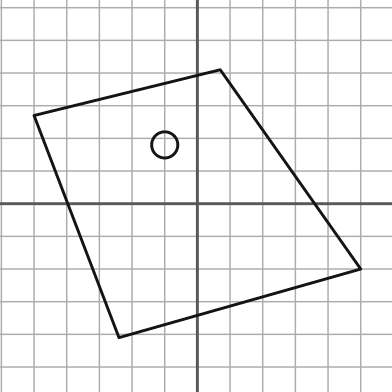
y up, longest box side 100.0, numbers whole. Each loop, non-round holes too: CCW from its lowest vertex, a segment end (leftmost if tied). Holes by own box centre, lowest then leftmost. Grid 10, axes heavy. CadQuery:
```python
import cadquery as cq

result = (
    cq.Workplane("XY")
    .moveTo(-24.0, -41.0)
    .lineTo(50.0, -20.0)
    .lineTo(7.0, 41.0)
    .lineTo(-50.0, 27.0)
    .close()
    .moveTo(-10.0, 18.0)
    .circle(4.0)
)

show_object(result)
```